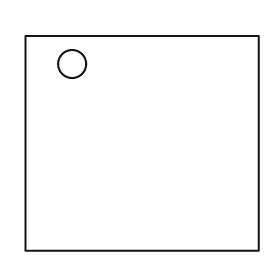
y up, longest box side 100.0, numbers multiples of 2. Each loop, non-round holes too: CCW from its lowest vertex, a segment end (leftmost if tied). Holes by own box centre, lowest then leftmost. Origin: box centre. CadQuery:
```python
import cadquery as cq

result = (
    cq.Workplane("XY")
    .moveTo(-50.0, -46.0)
    .lineTo(50.0, -46.0)
    .lineTo(50.0, 46.0)
    .lineTo(-50.0, 46.0)
    .close()
    .moveTo(-30.0, 34.0)
    .circle(6.0)
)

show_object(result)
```